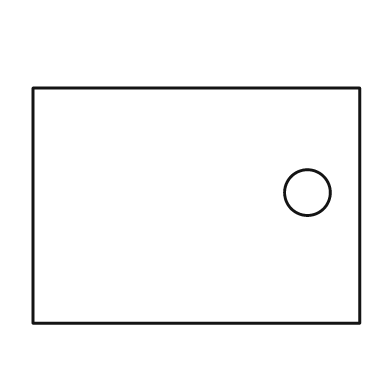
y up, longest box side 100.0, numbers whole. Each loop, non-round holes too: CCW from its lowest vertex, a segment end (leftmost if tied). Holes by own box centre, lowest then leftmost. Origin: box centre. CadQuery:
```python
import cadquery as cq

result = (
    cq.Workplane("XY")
    .moveTo(-50.0, -36.0)
    .lineTo(50.0, -36.0)
    .lineTo(50.0, 36.0)
    .lineTo(-50.0, 36.0)
    .close()
    .moveTo(34.0, 4.0)
    .circle(7.0)
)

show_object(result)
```